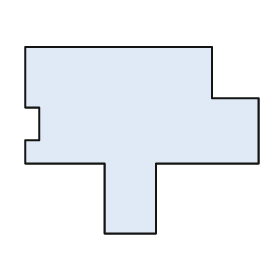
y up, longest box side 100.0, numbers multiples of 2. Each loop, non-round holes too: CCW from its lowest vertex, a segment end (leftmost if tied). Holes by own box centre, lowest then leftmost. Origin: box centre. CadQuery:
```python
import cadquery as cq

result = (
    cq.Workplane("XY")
    .moveTo(-16.0, -40.0)
    .lineTo(6.0, -40.0)
    .lineTo(6.0, -10.0)
    .lineTo(50.0, -10.0)
    .lineTo(50.0, 18.0)
    .lineTo(30.0, 18.0)
    .lineTo(30.0, 40.0)
    .lineTo(-50.0, 40.0)
    .lineTo(-50.0, 14.0)
    .lineTo(-44.0, 14.0)
    .lineTo(-44.0, 0.0)
    .lineTo(-50.0, 0.0)
    .lineTo(-50.0, -10.0)
    .lineTo(-16.0, -10.0)
    .close()
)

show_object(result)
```